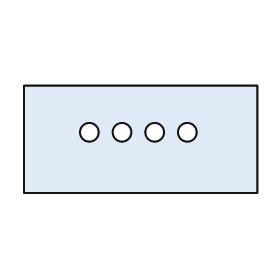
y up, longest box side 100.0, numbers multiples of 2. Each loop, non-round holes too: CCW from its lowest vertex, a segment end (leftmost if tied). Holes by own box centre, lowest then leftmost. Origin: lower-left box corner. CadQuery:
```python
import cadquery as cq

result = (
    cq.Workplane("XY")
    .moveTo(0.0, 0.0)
    .lineTo(100.0, 0.0)
    .lineTo(100.0, 46.0)
    .lineTo(0.0, 46.0)
    .close()
    .moveTo(28.0, 26.0)
    .circle(4.0)
    .moveTo(42.0, 26.0)
    .circle(4.0)
    .moveTo(56.0, 26.0)
    .circle(4.0)
    .moveTo(70.0, 26.0)
    .circle(4.0)
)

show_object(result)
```